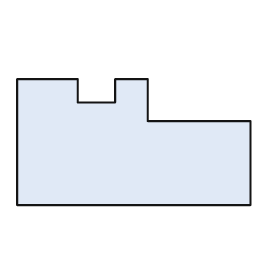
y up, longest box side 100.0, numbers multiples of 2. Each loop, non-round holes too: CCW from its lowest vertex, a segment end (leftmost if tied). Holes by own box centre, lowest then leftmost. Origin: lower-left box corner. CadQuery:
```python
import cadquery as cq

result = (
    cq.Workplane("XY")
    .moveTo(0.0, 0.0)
    .lineTo(100.0, 0.0)
    .lineTo(100.0, 36.0)
    .lineTo(56.0, 36.0)
    .lineTo(56.0, 54.0)
    .lineTo(42.0, 54.0)
    .lineTo(42.0, 44.0)
    .lineTo(26.0, 44.0)
    .lineTo(26.0, 54.0)
    .lineTo(0.0, 54.0)
    .close()
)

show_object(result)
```